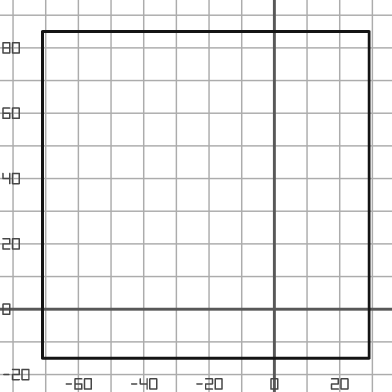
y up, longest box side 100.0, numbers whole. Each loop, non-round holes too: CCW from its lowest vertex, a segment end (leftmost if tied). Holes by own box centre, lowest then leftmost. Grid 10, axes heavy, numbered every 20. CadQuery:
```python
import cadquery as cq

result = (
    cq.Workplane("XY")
    .moveTo(-71.0, -15.0)
    .lineTo(29.0, -15.0)
    .lineTo(29.0, 85.0)
    .lineTo(-71.0, 85.0)
    .close()
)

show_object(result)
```